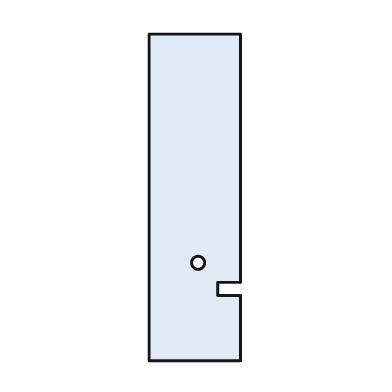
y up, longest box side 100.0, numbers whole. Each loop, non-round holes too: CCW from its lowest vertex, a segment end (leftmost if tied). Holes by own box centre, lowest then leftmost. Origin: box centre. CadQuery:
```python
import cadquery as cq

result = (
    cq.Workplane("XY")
    .moveTo(-14.0, -50.0)
    .lineTo(14.0, -50.0)
    .lineTo(14.0, -30.0)
    .lineTo(7.0, -30.0)
    .lineTo(7.0, -26.0)
    .lineTo(14.0, -26.0)
    .lineTo(14.0, 50.0)
    .lineTo(-14.0, 50.0)
    .close()
    .moveTo(1.0, -20.0)
    .circle(2.0)
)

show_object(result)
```